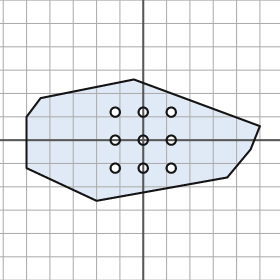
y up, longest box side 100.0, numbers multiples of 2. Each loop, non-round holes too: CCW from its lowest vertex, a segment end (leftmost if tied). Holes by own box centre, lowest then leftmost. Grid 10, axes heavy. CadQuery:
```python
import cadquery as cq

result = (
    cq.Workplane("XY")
    .moveTo(-20.0, -26.0)
    .lineTo(36.0, -16.0)
    .lineTo(46.0, -4.0)
    .lineTo(50.0, 6.0)
    .lineTo(-4.0, 26.0)
    .lineTo(-44.0, 18.0)
    .lineTo(-50.0, 10.0)
    .lineTo(-50.0, -12.0)
    .close()
    .moveTo(-12.0, -12.0)
    .circle(2.0)
    .moveTo(0.0, -12.0)
    .circle(2.0)
    .moveTo(12.0, -12.0)
    .circle(2.0)
    .moveTo(-12.0, 0.0)
    .circle(2.0)
    .moveTo(0.0, 0.0)
    .circle(2.0)
    .moveTo(12.0, 0.0)
    .circle(2.0)
    .moveTo(-12.0, 12.0)
    .circle(2.0)
    .moveTo(0.0, 12.0)
    .circle(2.0)
    .moveTo(12.0, 12.0)
    .circle(2.0)
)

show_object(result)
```